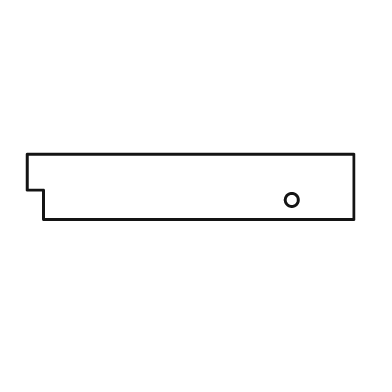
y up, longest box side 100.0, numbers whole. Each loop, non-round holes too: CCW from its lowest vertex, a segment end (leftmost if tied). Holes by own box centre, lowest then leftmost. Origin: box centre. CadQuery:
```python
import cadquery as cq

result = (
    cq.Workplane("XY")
    .moveTo(-45.0, -10.0)
    .lineTo(50.0, -10.0)
    .lineTo(50.0, 10.0)
    .lineTo(-50.0, 10.0)
    .lineTo(-50.0, -1.0)
    .lineTo(-45.0, -1.0)
    .close()
    .moveTo(31.0, -4.0)
    .circle(2.0)
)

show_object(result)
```